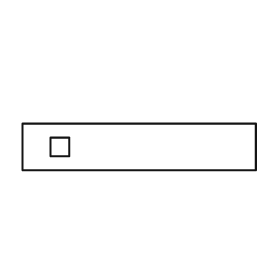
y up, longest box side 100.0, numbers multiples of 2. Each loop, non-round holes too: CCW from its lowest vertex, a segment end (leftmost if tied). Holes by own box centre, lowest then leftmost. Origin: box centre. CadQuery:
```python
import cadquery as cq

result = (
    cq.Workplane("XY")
    .moveTo(-50.0, -10.0)
    .lineTo(50.0, -10.0)
    .lineTo(50.0, 10.0)
    .lineTo(-50.0, 10.0)
    .close()
    .moveTo(-38.0, -4.0)
    .lineTo(-30.0, -4.0)
    .lineTo(-30.0, 4.0)
    .lineTo(-38.0, 4.0)
    .close()
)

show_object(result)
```